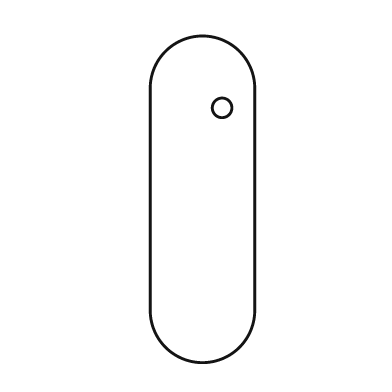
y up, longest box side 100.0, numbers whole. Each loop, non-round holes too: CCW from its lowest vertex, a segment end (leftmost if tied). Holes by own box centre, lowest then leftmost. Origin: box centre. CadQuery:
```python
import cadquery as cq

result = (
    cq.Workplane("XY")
    .moveTo(-16.0, -34.0)
    .threePointArc((0.0, -50.0), (16.0, -34.0))
    .lineTo(16.0, 34.0)
    .threePointArc((0.0, 50.0), (-16.0, 34.0))
    .close()
    .moveTo(6.0, 28.0)
    .circle(3.0)
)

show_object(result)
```